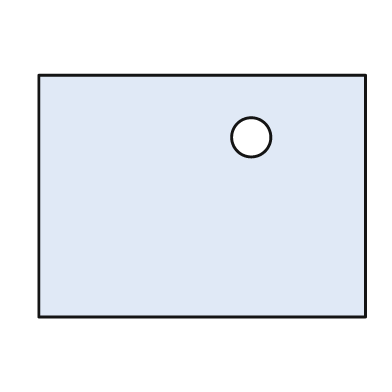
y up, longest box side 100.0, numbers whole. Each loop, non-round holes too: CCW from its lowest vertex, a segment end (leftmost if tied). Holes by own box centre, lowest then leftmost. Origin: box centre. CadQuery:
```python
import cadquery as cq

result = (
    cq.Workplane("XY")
    .moveTo(-50.0, -37.0)
    .lineTo(50.0, -37.0)
    .lineTo(50.0, 37.0)
    .lineTo(-50.0, 37.0)
    .close()
    .moveTo(15.0, 18.0)
    .circle(6.0)
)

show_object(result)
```